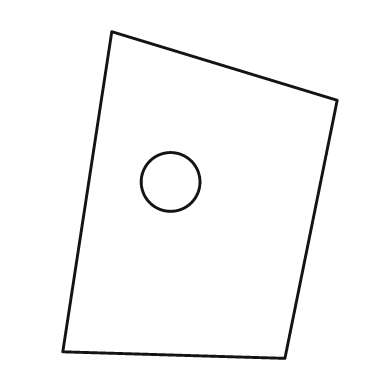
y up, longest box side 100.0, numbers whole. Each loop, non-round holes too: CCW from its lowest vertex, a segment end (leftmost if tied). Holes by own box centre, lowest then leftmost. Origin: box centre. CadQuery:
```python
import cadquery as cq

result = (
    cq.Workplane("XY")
    .moveTo(26.0, -50.0)
    .lineTo(42.0, 29.0)
    .lineTo(-27.0, 50.0)
    .lineTo(-42.0, -48.0)
    .close()
    .moveTo(-9.0, 4.0)
    .circle(9.0)
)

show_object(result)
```